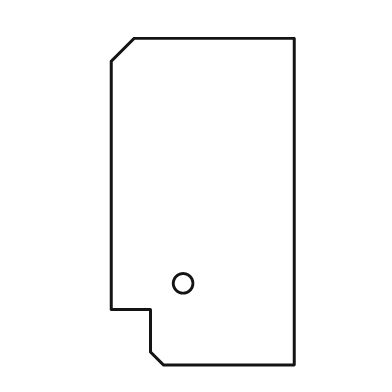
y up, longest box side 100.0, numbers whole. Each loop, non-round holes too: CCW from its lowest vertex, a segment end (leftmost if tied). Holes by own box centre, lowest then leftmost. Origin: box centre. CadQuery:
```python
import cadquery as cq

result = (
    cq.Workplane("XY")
    .moveTo(-12.0, -50.0)
    .lineTo(28.0, -50.0)
    .lineTo(28.0, 50.0)
    .lineTo(-21.0, 50.0)
    .lineTo(-28.0, 43.0)
    .lineTo(-28.0, -33.0)
    .lineTo(-16.0, -33.0)
    .lineTo(-16.0, -46.0)
    .close()
    .moveTo(-6.0, -25.0)
    .circle(3.0)
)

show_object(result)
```